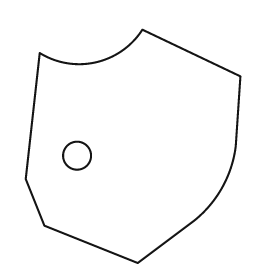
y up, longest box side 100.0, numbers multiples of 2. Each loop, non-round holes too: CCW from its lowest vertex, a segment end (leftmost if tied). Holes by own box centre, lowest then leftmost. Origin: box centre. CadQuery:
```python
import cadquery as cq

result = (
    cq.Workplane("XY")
    .moveTo(2.0, -50.0)
    .lineTo(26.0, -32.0)
    .threePointArc((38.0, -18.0), (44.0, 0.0))
    .lineTo(46.0, 30.0)
    .lineTo(4.0, 50.0)
    .threePointArc((-16.0, 36.0), (-40.0, 40.0))
    .lineTo(-46.0, -14.0)
    .lineTo(-38.0, -34.0)
    .close()
    .moveTo(-24.0, -4.0)
    .circle(6.0)
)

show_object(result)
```